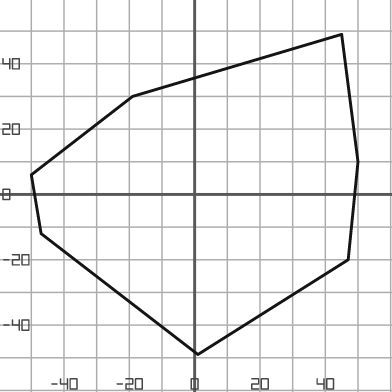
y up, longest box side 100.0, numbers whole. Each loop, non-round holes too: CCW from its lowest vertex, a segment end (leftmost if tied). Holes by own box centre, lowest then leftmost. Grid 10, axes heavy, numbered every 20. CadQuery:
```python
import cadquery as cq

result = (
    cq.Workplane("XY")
    .moveTo(1.0, -49.0)
    .lineTo(47.0, -20.0)
    .lineTo(50.0, 10.0)
    .lineTo(45.0, 49.0)
    .lineTo(-19.0, 30.0)
    .lineTo(-50.0, 6.0)
    .lineTo(-47.0, -12.0)
    .close()
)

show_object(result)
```